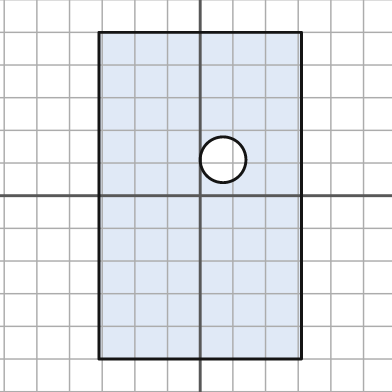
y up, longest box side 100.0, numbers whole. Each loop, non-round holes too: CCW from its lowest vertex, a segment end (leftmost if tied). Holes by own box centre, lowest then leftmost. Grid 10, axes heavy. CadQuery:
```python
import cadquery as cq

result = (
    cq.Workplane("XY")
    .moveTo(-31.0, -50.0)
    .lineTo(31.0, -50.0)
    .lineTo(31.0, 50.0)
    .lineTo(-31.0, 50.0)
    .close()
    .moveTo(7.0, 11.0)
    .circle(7.0)
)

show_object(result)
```